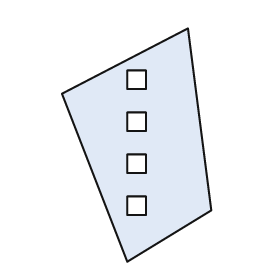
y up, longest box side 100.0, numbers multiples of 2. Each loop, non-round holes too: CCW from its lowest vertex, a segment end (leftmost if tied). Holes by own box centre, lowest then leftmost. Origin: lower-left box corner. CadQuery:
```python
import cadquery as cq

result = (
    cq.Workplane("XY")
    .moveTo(28.0, 0.0)
    .lineTo(64.0, 22.0)
    .lineTo(54.0, 100.0)
    .lineTo(0.0, 72.0)
    .close()
    .moveTo(28.0, 20.0)
    .lineTo(36.0, 20.0)
    .lineTo(36.0, 28.0)
    .lineTo(28.0, 28.0)
    .close()
    .moveTo(28.0, 38.0)
    .lineTo(36.0, 38.0)
    .lineTo(36.0, 46.0)
    .lineTo(28.0, 46.0)
    .close()
    .moveTo(28.0, 56.0)
    .lineTo(36.0, 56.0)
    .lineTo(36.0, 64.0)
    .lineTo(28.0, 64.0)
    .close()
    .moveTo(28.0, 74.0)
    .lineTo(36.0, 74.0)
    .lineTo(36.0, 82.0)
    .lineTo(28.0, 82.0)
    .close()
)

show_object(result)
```